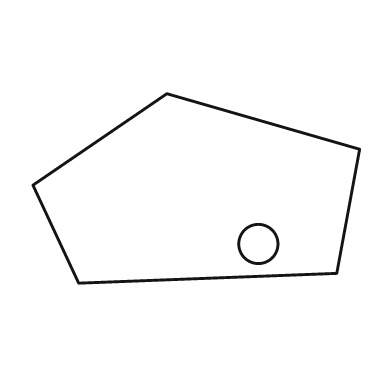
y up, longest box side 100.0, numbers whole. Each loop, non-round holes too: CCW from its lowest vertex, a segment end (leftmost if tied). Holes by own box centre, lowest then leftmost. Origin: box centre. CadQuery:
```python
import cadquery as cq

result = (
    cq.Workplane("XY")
    .moveTo(-36.0, -29.0)
    .lineTo(43.0, -26.0)
    .lineTo(50.0, 12.0)
    .lineTo(-9.0, 29.0)
    .lineTo(-50.0, 1.0)
    .close()
    .moveTo(19.0, -17.0)
    .circle(6.0)
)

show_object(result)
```